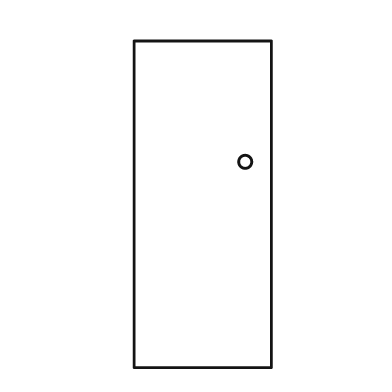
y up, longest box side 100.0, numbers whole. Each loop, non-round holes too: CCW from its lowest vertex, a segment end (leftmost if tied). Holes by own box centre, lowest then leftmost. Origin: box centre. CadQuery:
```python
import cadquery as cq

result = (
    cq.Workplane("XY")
    .moveTo(-21.0, -50.0)
    .lineTo(21.0, -50.0)
    .lineTo(21.0, 50.0)
    .lineTo(-21.0, 50.0)
    .close()
    .moveTo(13.0, 13.0)
    .circle(2.0)
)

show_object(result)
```